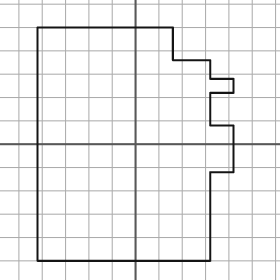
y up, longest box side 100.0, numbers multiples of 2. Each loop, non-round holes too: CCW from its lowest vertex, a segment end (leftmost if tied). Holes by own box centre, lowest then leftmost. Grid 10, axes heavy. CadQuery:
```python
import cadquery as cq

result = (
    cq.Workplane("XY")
    .moveTo(-42.0, -50.0)
    .lineTo(32.0, -50.0)
    .lineTo(32.0, -12.0)
    .lineTo(42.0, -12.0)
    .lineTo(42.0, 8.0)
    .lineTo(32.0, 8.0)
    .lineTo(32.0, 22.0)
    .lineTo(42.0, 22.0)
    .lineTo(42.0, 28.0)
    .lineTo(32.0, 28.0)
    .lineTo(32.0, 36.0)
    .lineTo(16.0, 36.0)
    .lineTo(16.0, 50.0)
    .lineTo(-42.0, 50.0)
    .close()
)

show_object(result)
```